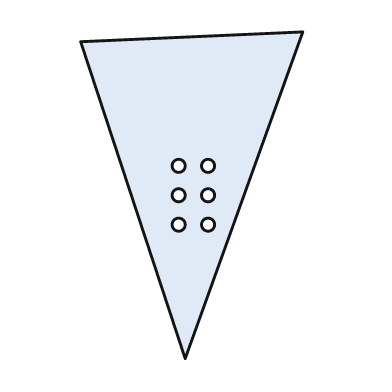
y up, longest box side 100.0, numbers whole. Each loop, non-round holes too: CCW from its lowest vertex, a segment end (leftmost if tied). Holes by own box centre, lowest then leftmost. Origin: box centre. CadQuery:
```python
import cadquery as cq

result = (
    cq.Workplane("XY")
    .moveTo(-2.0, -50.0)
    .lineTo(34.0, 50.0)
    .lineTo(-34.0, 47.0)
    .close()
    .moveTo(-4.0, -9.0)
    .circle(2.0)
    .moveTo(5.0, -9.0)
    .circle(2.0)
    .moveTo(-4.0, 0.0)
    .circle(2.0)
    .moveTo(5.0, 0.0)
    .circle(2.0)
    .moveTo(-4.0, 9.0)
    .circle(2.0)
    .moveTo(5.0, 9.0)
    .circle(2.0)
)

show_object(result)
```